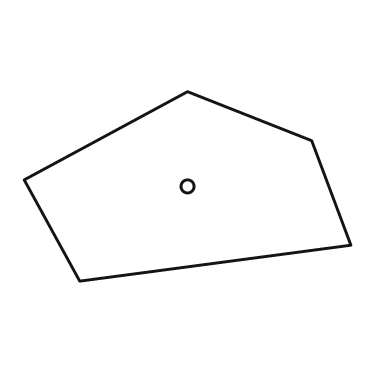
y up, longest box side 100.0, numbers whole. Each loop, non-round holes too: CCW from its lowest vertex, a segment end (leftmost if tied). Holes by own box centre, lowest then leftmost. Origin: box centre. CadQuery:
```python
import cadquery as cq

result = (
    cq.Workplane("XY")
    .moveTo(-33.0, -29.0)
    .lineTo(50.0, -18.0)
    .lineTo(38.0, 14.0)
    .lineTo(0.0, 29.0)
    .lineTo(-50.0, 2.0)
    .close()
    .moveTo(0.0, 0.0)
    .circle(2.0)
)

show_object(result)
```